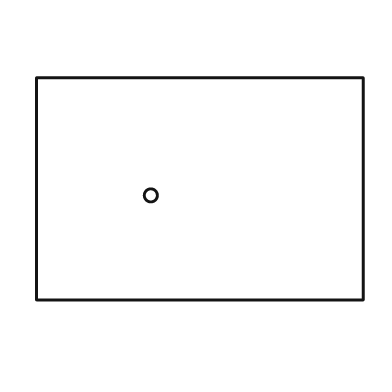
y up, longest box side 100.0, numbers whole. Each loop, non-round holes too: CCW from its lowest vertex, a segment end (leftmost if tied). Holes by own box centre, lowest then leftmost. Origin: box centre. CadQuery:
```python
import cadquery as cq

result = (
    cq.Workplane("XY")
    .moveTo(-50.0, -34.0)
    .lineTo(50.0, -34.0)
    .lineTo(50.0, 34.0)
    .lineTo(-50.0, 34.0)
    .close()
    .moveTo(-15.0, -2.0)
    .circle(2.0)
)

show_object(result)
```